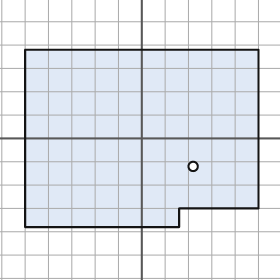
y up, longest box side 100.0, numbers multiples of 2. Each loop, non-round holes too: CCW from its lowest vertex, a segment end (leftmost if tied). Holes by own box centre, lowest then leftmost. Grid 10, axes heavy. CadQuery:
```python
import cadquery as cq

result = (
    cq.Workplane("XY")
    .moveTo(-50.0, -38.0)
    .lineTo(16.0, -38.0)
    .lineTo(16.0, -30.0)
    .lineTo(50.0, -30.0)
    .lineTo(50.0, 38.0)
    .lineTo(-50.0, 38.0)
    .close()
    .moveTo(22.0, -12.0)
    .circle(2.0)
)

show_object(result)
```